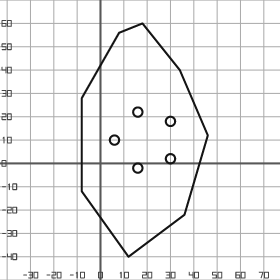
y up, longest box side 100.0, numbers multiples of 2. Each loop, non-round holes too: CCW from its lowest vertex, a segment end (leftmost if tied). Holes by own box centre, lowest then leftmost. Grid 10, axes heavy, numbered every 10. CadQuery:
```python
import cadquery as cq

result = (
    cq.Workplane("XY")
    .moveTo(12.0, -40.0)
    .lineTo(36.0, -22.0)
    .lineTo(46.0, 12.0)
    .lineTo(34.0, 40.0)
    .lineTo(18.0, 60.0)
    .lineTo(8.0, 56.0)
    .lineTo(-8.0, 28.0)
    .lineTo(-8.0, -12.0)
    .close()
    .moveTo(16.0, -2.0)
    .circle(2.0)
    .moveTo(30.0, 2.0)
    .circle(2.0)
    .moveTo(6.0, 10.0)
    .circle(2.0)
    .moveTo(30.0, 18.0)
    .circle(2.0)
    .moveTo(16.0, 22.0)
    .circle(2.0)
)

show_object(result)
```